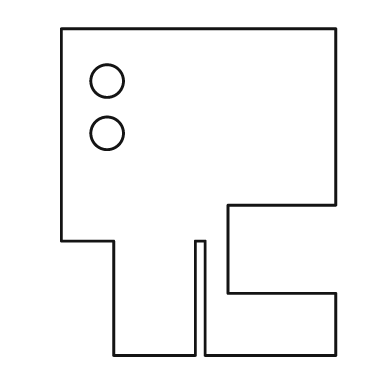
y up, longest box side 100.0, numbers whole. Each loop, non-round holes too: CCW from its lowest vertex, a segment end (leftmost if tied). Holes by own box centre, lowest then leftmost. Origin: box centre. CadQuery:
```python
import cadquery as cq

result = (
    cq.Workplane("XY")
    .moveTo(-26.0, -50.0)
    .lineTo(-1.0, -50.0)
    .lineTo(-1.0, -15.0)
    .lineTo(2.0, -15.0)
    .lineTo(2.0, -50.0)
    .lineTo(42.0, -50.0)
    .lineTo(42.0, -31.0)
    .lineTo(9.0, -31.0)
    .lineTo(9.0, -4.0)
    .lineTo(42.0, -4.0)
    .lineTo(42.0, 50.0)
    .lineTo(-42.0, 50.0)
    .lineTo(-42.0, -15.0)
    .lineTo(-26.0, -15.0)
    .close()
    .moveTo(-28.0, 18.0)
    .circle(5.0)
    .moveTo(-28.0, 34.0)
    .circle(5.0)
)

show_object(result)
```